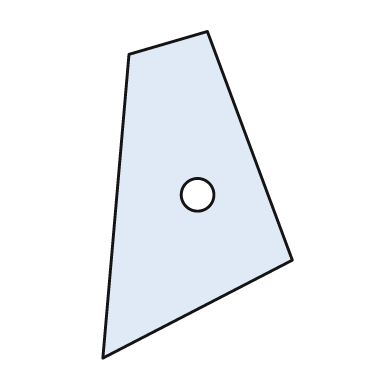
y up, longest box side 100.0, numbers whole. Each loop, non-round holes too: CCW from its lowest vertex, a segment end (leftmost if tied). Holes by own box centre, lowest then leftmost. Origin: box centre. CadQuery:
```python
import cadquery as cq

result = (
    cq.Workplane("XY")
    .moveTo(-29.0, -50.0)
    .lineTo(29.0, -20.0)
    .lineTo(3.0, 50.0)
    .lineTo(-21.0, 43.0)
    .close()
    .moveTo(0.0, 0.0)
    .circle(5.0)
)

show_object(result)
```